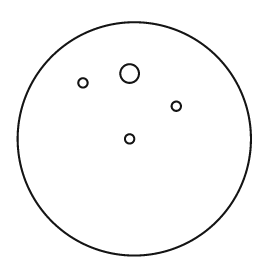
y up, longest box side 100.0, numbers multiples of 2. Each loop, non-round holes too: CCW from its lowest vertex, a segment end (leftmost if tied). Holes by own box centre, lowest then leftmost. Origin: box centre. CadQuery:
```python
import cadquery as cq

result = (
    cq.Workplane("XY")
    .moveTo(0.0, 0.0)
    .circle(50.0)
    .moveTo(-2.0, 0.0)
    .circle(2.0)
    .moveTo(18.0, 14.0)
    .circle(2.0)
    .moveTo(-22.0, 24.0)
    .circle(2.0)
    .moveTo(-2.0, 28.0)
    .circle(4.0)
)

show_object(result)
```